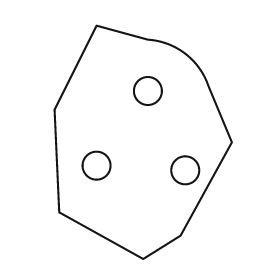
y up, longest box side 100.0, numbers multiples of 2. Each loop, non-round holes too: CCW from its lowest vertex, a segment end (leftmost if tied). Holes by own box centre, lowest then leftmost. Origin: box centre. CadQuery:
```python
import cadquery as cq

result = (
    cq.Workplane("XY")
    .moveTo(0.0, -50.0)
    .lineTo(16.0, -40.0)
    .lineTo(38.0, 0.0)
    .lineTo(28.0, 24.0)
    .threePointArc((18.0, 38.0), (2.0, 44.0))
    .lineTo(-20.0, 50.0)
    .lineTo(-38.0, 14.0)
    .lineTo(-36.0, -30.0)
    .close()
    .moveTo(18.0, -12.0)
    .circle(6.0)
    .moveTo(-20.0, -10.0)
    .circle(6.0)
    .moveTo(2.0, 22.0)
    .circle(6.0)
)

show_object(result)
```